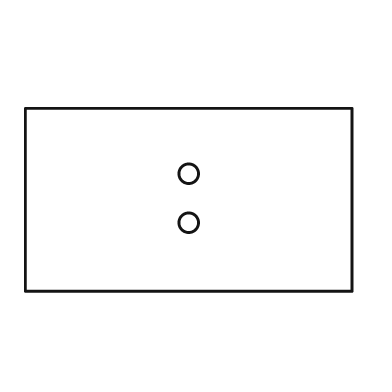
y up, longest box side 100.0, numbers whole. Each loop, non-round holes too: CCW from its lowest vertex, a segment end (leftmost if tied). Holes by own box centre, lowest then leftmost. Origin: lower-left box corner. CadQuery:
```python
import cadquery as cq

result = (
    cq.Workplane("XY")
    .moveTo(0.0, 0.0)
    .lineTo(100.0, 0.0)
    .lineTo(100.0, 56.0)
    .lineTo(0.0, 56.0)
    .close()
    .moveTo(50.0, 21.0)
    .circle(3.0)
    .moveTo(50.0, 36.0)
    .circle(3.0)
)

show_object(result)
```